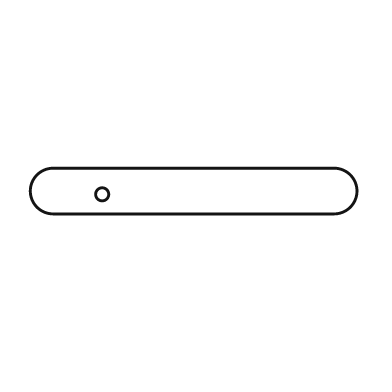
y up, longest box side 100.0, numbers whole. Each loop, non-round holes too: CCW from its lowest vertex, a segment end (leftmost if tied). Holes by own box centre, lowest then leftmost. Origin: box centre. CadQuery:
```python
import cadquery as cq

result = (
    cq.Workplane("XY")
    .moveTo(-43.0, -7.0)
    .lineTo(43.0, -7.0)
    .threePointArc((50.0, 0.0), (43.0, 7.0))
    .lineTo(-43.0, 7.0)
    .threePointArc((-50.0, 0.0), (-43.0, -7.0))
    .close()
    .moveTo(-28.0, -1.0)
    .circle(2.0)
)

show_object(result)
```